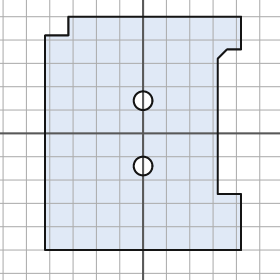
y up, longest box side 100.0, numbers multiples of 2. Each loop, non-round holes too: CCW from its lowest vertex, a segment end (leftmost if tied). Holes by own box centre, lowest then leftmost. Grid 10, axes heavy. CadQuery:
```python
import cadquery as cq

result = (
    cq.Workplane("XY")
    .moveTo(-42.0, -50.0)
    .lineTo(42.0, -50.0)
    .lineTo(42.0, -26.0)
    .lineTo(32.0, -26.0)
    .lineTo(32.0, 32.0)
    .lineTo(36.0, 36.0)
    .lineTo(42.0, 36.0)
    .lineTo(42.0, 50.0)
    .lineTo(-32.0, 50.0)
    .lineTo(-32.0, 42.0)
    .lineTo(-42.0, 42.0)
    .close()
    .moveTo(0.0, -14.0)
    .circle(4.0)
    .moveTo(0.0, 14.0)
    .circle(4.0)
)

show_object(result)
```